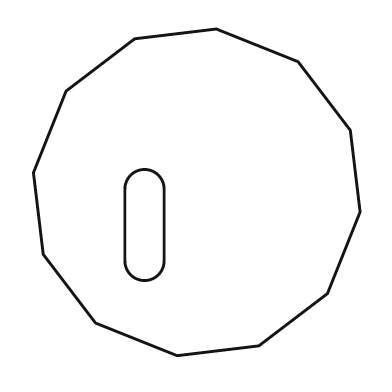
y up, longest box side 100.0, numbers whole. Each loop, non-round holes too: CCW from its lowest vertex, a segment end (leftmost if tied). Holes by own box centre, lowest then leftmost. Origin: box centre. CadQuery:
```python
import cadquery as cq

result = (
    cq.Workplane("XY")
    .moveTo(-6.0, -50.0)
    .lineTo(19.0, -47.0)
    .lineTo(40.0, -31.0)
    .lineTo(50.0, -6.0)
    .lineTo(47.0, 19.0)
    .lineTo(31.0, 40.0)
    .lineTo(6.0, 50.0)
    .lineTo(-19.0, 47.0)
    .lineTo(-40.0, 31.0)
    .lineTo(-50.0, 6.0)
    .lineTo(-47.0, -19.0)
    .lineTo(-31.0, -40.0)
    .close()
    .moveTo(-22.0, -21.0)
    .threePointArc((-16.0, -27.0), (-10.0, -21.0))
    .lineTo(-10.0, 1.0)
    .threePointArc((-16.0, 7.0), (-22.0, 1.0))
    .close()
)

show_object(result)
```